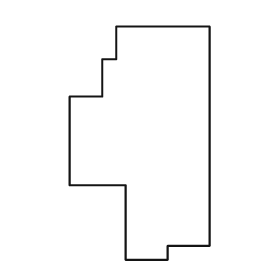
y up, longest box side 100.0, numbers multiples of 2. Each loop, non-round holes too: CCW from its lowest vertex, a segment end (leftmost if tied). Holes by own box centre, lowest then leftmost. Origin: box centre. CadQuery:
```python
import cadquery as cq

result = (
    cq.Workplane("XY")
    .moveTo(-6.0, -50.0)
    .lineTo(12.0, -50.0)
    .lineTo(12.0, -44.0)
    .lineTo(30.0, -44.0)
    .lineTo(30.0, 50.0)
    .lineTo(-10.0, 50.0)
    .lineTo(-10.0, 36.0)
    .lineTo(-16.0, 36.0)
    .lineTo(-16.0, 20.0)
    .lineTo(-30.0, 20.0)
    .lineTo(-30.0, -18.0)
    .lineTo(-6.0, -18.0)
    .close()
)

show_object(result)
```